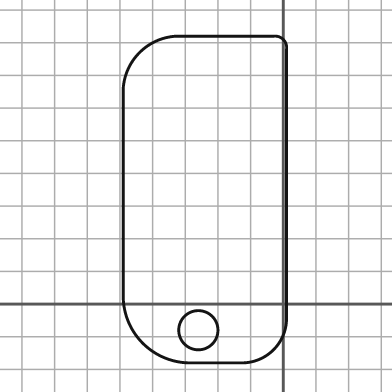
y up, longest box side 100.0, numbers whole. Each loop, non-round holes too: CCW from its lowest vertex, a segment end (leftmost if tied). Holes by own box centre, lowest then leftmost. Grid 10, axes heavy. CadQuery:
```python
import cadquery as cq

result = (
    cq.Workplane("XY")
    .moveTo(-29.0, -18.0)
    .lineTo(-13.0, -18.0)
    .threePointArc((-3.0, -14.0), (1.0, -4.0))
    .lineTo(1.0, 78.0)
    .threePointArc((0.0, 81.0), (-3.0, 82.0))
    .lineTo(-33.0, 82.0)
    .threePointArc((-44.0, 77.0), (-49.0, 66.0))
    .lineTo(-49.0, 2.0)
    .threePointArc((-43.0, -12.0), (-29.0, -18.0))
    .close()
    .moveTo(-26.0, -8.0)
    .circle(6.0)
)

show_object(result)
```